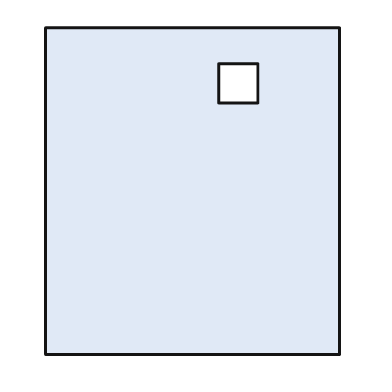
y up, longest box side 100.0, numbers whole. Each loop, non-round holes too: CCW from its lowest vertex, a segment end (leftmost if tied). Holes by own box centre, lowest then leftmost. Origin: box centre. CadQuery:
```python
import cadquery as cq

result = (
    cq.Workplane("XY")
    .moveTo(-45.0, -50.0)
    .lineTo(45.0, -50.0)
    .lineTo(45.0, 50.0)
    .lineTo(-45.0, 50.0)
    .close()
    .moveTo(8.0, 27.0)
    .lineTo(20.0, 27.0)
    .lineTo(20.0, 39.0)
    .lineTo(8.0, 39.0)
    .close()
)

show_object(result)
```